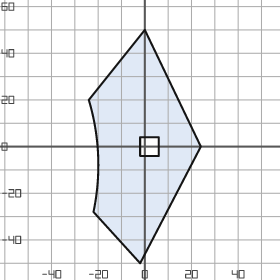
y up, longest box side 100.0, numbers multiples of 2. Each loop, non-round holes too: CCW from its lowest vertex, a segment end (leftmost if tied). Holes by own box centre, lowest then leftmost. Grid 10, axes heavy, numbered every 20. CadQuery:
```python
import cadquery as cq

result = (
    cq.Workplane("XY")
    .moveTo(-2.0, -50.0)
    .lineTo(24.0, 0.0)
    .lineTo(0.0, 50.0)
    .lineTo(-24.0, 20.0)
    .threePointArc((-20.0, -4.0), (-22.0, -28.0))
    .close()
    .moveTo(-2.0, -4.0)
    .lineTo(6.0, -4.0)
    .lineTo(6.0, 4.0)
    .lineTo(-2.0, 4.0)
    .close()
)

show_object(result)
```